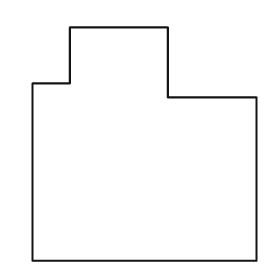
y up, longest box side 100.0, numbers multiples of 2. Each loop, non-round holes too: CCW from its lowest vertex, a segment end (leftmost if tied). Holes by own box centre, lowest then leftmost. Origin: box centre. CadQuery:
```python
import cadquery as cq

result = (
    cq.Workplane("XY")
    .moveTo(-48.0, -50.0)
    .lineTo(48.0, -50.0)
    .lineTo(48.0, 20.0)
    .lineTo(10.0, 20.0)
    .lineTo(10.0, 50.0)
    .lineTo(-32.0, 50.0)
    .lineTo(-32.0, 26.0)
    .lineTo(-48.0, 26.0)
    .close()
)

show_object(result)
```